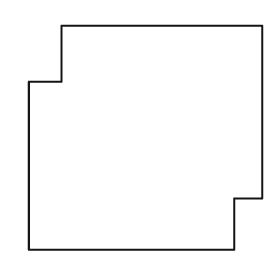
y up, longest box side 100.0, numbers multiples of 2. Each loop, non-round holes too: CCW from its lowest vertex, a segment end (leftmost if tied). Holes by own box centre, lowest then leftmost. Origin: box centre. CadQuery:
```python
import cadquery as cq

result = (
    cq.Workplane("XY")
    .moveTo(-50.0, -48.0)
    .lineTo(38.0, -48.0)
    .lineTo(38.0, -26.0)
    .lineTo(50.0, -26.0)
    .lineTo(50.0, 48.0)
    .lineTo(-36.0, 48.0)
    .lineTo(-36.0, 24.0)
    .lineTo(-50.0, 24.0)
    .close()
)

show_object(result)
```